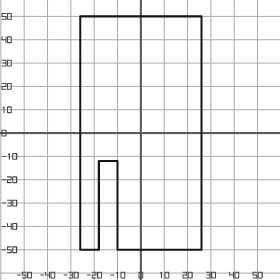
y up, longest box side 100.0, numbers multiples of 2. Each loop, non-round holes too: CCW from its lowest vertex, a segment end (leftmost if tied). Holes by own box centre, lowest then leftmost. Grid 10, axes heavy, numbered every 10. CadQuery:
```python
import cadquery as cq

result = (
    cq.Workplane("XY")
    .moveTo(-26.0, -50.0)
    .lineTo(-18.0, -50.0)
    .lineTo(-18.0, -12.0)
    .lineTo(-10.0, -12.0)
    .lineTo(-10.0, -50.0)
    .lineTo(26.0, -50.0)
    .lineTo(26.0, 50.0)
    .lineTo(-26.0, 50.0)
    .close()
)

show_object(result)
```